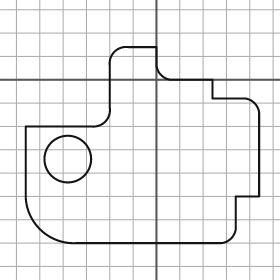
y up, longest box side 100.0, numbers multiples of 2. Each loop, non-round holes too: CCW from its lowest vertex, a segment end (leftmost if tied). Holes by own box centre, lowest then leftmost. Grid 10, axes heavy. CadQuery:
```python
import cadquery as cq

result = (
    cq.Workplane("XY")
    .moveTo(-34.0, -70.0)
    .lineTo(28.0, -70.0)
    .threePointArc((32.0, -68.0), (34.0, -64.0))
    .lineTo(34.0, -50.0)
    .lineTo(44.0, -50.0)
    .lineTo(44.0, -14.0)
    .threePointArc((42.0, -10.0), (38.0, -8.0))
    .lineTo(24.0, -8.0)
    .lineTo(24.0, 0.0)
    .lineTo(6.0, 0.0)
    .threePointArc((2.0, 2.0), (0.0, 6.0))
    .lineTo(0.0, 14.0)
    .lineTo(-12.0, 14.0)
    .threePointArc((-18.0, 12.0), (-20.0, 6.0))
    .lineTo(-20.0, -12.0)
    .threePointArc((-22.0, -18.0), (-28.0, -20.0))
    .lineTo(-56.0, -20.0)
    .lineTo(-56.0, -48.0)
    .threePointArc((-50.0, -64.0), (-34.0, -70.0))
    .close()
    .moveTo(-38.0, -34.0)
    .circle(10.0)
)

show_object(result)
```